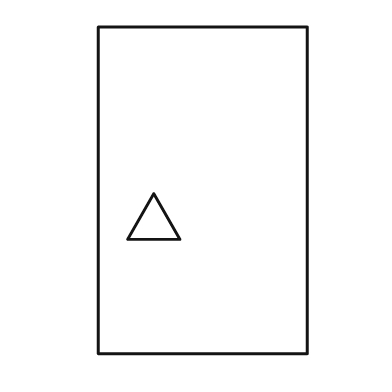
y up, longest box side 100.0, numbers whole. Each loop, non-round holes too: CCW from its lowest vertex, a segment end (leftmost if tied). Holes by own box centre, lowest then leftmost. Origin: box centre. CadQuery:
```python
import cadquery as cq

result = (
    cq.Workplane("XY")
    .moveTo(-32.0, -50.0)
    .lineTo(32.0, -50.0)
    .lineTo(32.0, 50.0)
    .lineTo(-32.0, 50.0)
    .close()
    .moveTo(-23.0, -15.0)
    .lineTo(-7.0, -15.0)
    .lineTo(-15.0, -1.0)
    .close()
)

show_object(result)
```